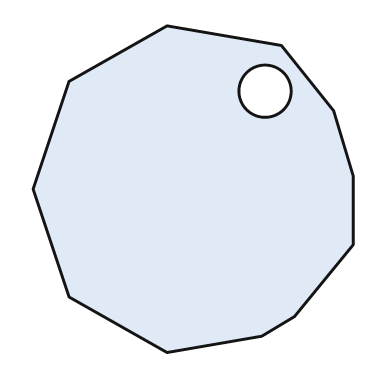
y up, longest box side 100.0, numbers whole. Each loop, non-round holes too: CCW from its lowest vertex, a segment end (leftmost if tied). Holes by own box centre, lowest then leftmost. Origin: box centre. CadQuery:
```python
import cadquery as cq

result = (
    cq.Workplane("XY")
    .moveTo(-8.0, -50.0)
    .lineTo(21.0, -45.0)
    .lineTo(31.0, -39.0)
    .lineTo(49.0, -17.0)
    .lineTo(49.0, 4.0)
    .lineTo(43.0, 24.0)
    .lineTo(27.0, 44.0)
    .lineTo(-8.0, 50.0)
    .lineTo(-38.0, 33.0)
    .lineTo(-49.0, 0.0)
    .lineTo(-38.0, -33.0)
    .close()
    .moveTo(22.0, 30.0)
    .circle(8.0)
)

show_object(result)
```